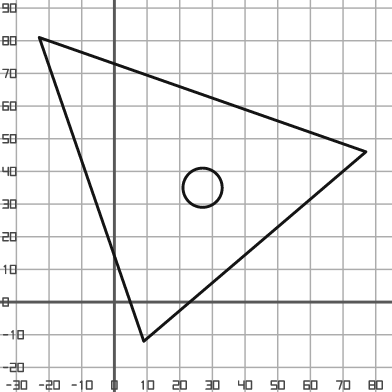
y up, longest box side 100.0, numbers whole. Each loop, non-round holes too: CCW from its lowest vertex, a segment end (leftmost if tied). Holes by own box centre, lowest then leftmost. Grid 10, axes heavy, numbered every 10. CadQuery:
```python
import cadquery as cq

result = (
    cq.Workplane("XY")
    .moveTo(9.0, -12.0)
    .lineTo(77.0, 46.0)
    .lineTo(-23.0, 81.0)
    .close()
    .moveTo(27.0, 35.0)
    .circle(6.0)
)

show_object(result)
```